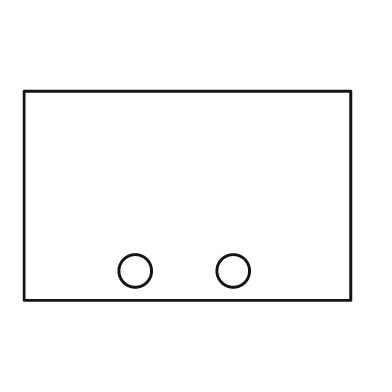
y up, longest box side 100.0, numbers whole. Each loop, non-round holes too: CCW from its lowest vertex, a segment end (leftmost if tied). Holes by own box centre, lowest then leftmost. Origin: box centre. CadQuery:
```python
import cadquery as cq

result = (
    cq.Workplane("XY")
    .moveTo(-50.0, -32.0)
    .lineTo(50.0, -32.0)
    .lineTo(50.0, 32.0)
    .lineTo(-50.0, 32.0)
    .close()
    .moveTo(-16.0, -23.0)
    .circle(5.0)
    .moveTo(14.0, -23.0)
    .circle(5.0)
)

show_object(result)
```